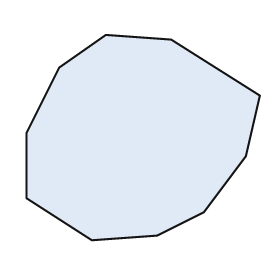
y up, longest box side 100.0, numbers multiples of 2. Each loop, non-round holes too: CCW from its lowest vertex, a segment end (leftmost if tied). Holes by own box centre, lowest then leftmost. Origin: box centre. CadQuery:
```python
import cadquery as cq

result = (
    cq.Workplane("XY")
    .moveTo(-22.0, -44.0)
    .lineTo(6.0, -42.0)
    .lineTo(26.0, -32.0)
    .lineTo(44.0, -8.0)
    .lineTo(50.0, 18.0)
    .lineTo(12.0, 42.0)
    .lineTo(-16.0, 44.0)
    .lineTo(-36.0, 30.0)
    .lineTo(-50.0, 2.0)
    .lineTo(-50.0, -26.0)
    .close()
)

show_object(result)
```